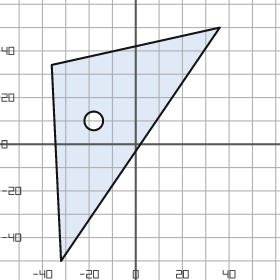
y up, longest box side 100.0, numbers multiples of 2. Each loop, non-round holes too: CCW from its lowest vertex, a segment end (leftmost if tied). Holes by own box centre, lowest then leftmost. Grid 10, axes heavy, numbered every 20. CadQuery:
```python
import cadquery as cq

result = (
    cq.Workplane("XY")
    .moveTo(-32.0, -50.0)
    .lineTo(36.0, 50.0)
    .lineTo(-36.0, 34.0)
    .close()
    .moveTo(-18.0, 10.0)
    .circle(4.0)
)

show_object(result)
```